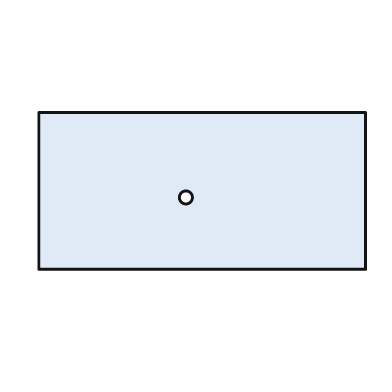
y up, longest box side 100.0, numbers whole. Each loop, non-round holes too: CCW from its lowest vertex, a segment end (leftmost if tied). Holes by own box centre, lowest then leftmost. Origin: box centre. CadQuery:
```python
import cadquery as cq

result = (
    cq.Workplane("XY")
    .moveTo(-50.0, -24.0)
    .lineTo(50.0, -24.0)
    .lineTo(50.0, 24.0)
    .lineTo(-50.0, 24.0)
    .close()
    .moveTo(-5.0, -2.0)
    .circle(2.0)
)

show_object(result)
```